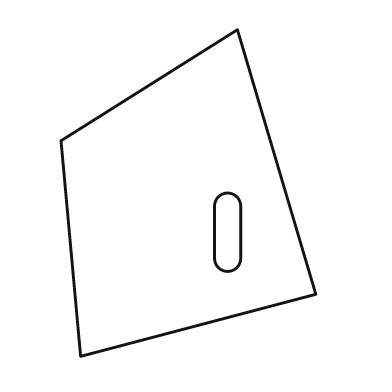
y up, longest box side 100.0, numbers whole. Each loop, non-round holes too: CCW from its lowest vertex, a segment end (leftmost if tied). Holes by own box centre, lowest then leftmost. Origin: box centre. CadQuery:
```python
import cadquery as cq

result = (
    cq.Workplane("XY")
    .moveTo(-33.0, -50.0)
    .lineTo(39.0, -31.0)
    .lineTo(15.0, 50.0)
    .lineTo(-39.0, 16.0)
    .close()
    .moveTo(8.0, -20.0)
    .threePointArc((12.0, -24.0), (16.0, -20.0))
    .lineTo(16.0, -4.0)
    .threePointArc((12.0, 0.0), (8.0, -4.0))
    .close()
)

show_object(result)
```